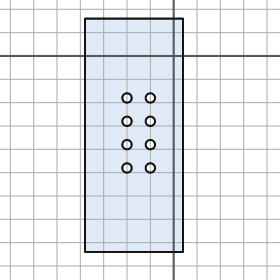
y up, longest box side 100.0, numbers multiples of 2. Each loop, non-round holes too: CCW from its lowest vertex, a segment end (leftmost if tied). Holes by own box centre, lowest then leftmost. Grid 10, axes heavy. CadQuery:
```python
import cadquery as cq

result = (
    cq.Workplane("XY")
    .moveTo(-38.0, -84.0)
    .lineTo(4.0, -84.0)
    .lineTo(4.0, 16.0)
    .lineTo(-38.0, 16.0)
    .close()
    .moveTo(-20.0, -48.0)
    .circle(2.0)
    .moveTo(-10.0, -48.0)
    .circle(2.0)
    .moveTo(-20.0, -38.0)
    .circle(2.0)
    .moveTo(-10.0, -38.0)
    .circle(2.0)
    .moveTo(-20.0, -28.0)
    .circle(2.0)
    .moveTo(-10.0, -28.0)
    .circle(2.0)
    .moveTo(-20.0, -18.0)
    .circle(2.0)
    .moveTo(-10.0, -18.0)
    .circle(2.0)
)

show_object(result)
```